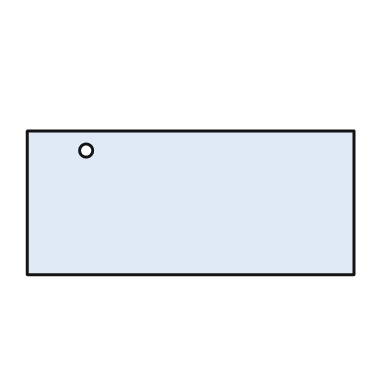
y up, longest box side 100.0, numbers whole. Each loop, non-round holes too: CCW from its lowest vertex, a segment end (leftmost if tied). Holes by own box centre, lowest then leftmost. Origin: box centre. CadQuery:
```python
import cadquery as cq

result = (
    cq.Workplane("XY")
    .moveTo(-50.0, -22.0)
    .lineTo(50.0, -22.0)
    .lineTo(50.0, 22.0)
    .lineTo(-50.0, 22.0)
    .close()
    .moveTo(-32.0, 16.0)
    .circle(2.0)
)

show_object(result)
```